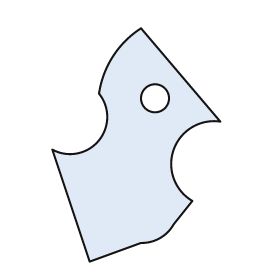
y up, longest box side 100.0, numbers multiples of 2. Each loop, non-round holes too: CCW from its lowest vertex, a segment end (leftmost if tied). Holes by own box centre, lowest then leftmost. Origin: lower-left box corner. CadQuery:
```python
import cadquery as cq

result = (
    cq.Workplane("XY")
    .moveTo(16.0, 0.0)
    .lineTo(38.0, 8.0)
    .threePointArc((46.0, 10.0), (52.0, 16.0))
    .lineTo(60.0, 26.0)
    .threePointArc((52.0, 48.0), (72.0, 60.0))
    .lineTo(38.0, 100.0)
    .threePointArc((26.0, 88.0), (20.0, 72.0))
    .threePointArc((20.0, 52.0), (0.0, 48.0))
    .close()
    .moveTo(44.0, 70.0)
    .circle(6.0)
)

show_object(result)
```